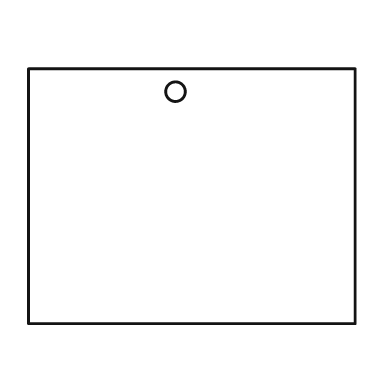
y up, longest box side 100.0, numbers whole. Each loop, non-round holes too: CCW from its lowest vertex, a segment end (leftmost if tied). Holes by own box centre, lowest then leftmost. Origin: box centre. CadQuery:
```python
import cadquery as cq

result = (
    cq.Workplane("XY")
    .moveTo(-50.0, -39.0)
    .lineTo(50.0, -39.0)
    .lineTo(50.0, 39.0)
    .lineTo(-50.0, 39.0)
    .close()
    .moveTo(-5.0, 32.0)
    .circle(3.0)
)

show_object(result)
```